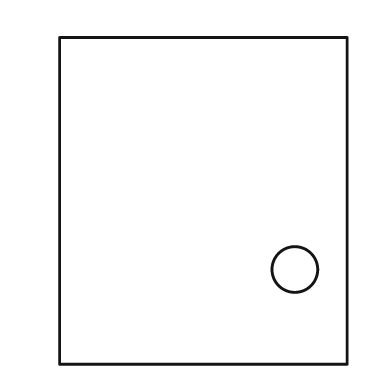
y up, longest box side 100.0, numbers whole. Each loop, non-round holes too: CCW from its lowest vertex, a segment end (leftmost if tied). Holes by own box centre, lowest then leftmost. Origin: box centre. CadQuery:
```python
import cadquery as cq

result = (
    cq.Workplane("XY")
    .moveTo(-44.0, -50.0)
    .lineTo(44.0, -50.0)
    .lineTo(44.0, 50.0)
    .lineTo(-44.0, 50.0)
    .close()
    .moveTo(28.0, -21.0)
    .circle(7.0)
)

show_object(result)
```